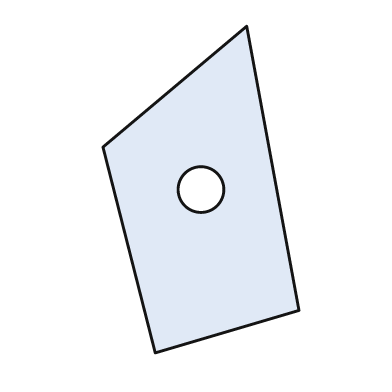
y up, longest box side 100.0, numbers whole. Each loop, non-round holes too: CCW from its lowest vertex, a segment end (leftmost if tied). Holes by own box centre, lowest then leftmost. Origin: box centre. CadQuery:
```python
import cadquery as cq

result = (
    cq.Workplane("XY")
    .moveTo(-14.0, -50.0)
    .lineTo(30.0, -37.0)
    .lineTo(14.0, 50.0)
    .lineTo(-30.0, 13.0)
    .close()
    .moveTo(0.0, 0.0)
    .circle(7.0)
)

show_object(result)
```